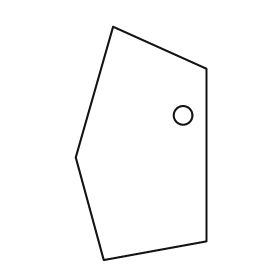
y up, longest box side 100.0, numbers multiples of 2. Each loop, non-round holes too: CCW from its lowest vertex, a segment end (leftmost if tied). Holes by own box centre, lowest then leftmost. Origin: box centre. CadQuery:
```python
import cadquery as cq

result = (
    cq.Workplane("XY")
    .moveTo(-16.0, -50.0)
    .lineTo(28.0, -42.0)
    .lineTo(28.0, 32.0)
    .lineTo(-12.0, 50.0)
    .lineTo(-28.0, -6.0)
    .close()
    .moveTo(18.0, 12.0)
    .circle(4.0)
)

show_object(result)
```